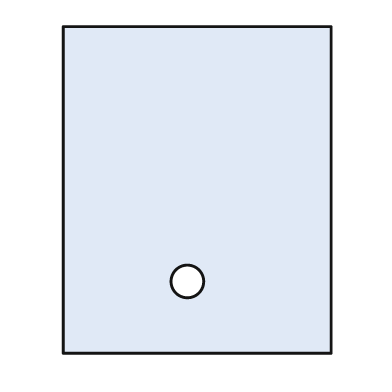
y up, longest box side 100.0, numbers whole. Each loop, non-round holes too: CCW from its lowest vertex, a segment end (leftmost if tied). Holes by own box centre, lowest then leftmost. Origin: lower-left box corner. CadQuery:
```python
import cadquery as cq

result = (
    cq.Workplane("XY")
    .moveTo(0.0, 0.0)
    .lineTo(82.0, 0.0)
    .lineTo(82.0, 100.0)
    .lineTo(0.0, 100.0)
    .close()
    .moveTo(38.0, 22.0)
    .circle(5.0)
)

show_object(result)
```